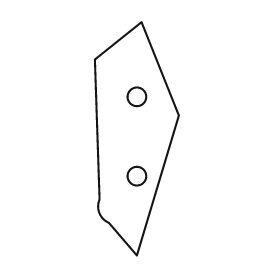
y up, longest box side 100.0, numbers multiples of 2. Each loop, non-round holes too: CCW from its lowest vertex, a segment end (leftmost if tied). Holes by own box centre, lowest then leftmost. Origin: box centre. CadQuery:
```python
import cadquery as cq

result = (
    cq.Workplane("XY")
    .moveTo(0.0, -50.0)
    .lineTo(18.0, 10.0)
    .lineTo(2.0, 50.0)
    .lineTo(-18.0, 34.0)
    .lineTo(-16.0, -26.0)
    .threePointArc((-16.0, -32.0), (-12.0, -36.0))
    .close()
    .moveTo(0.0, -16.0)
    .circle(4.0)
    .moveTo(0.0, 18.0)
    .circle(4.0)
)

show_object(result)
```